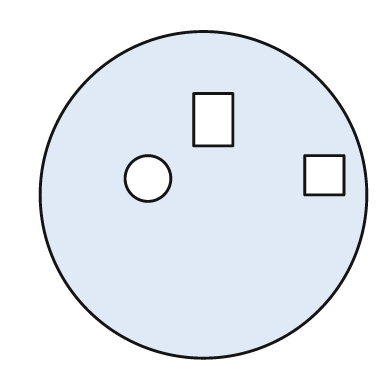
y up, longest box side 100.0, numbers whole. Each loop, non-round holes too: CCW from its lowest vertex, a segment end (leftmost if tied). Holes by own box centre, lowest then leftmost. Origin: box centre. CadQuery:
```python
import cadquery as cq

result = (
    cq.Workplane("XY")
    .moveTo(0.0, 0.0)
    .circle(50.0)
    .moveTo(-17.0, 5.0)
    .circle(7.0)
    .moveTo(31.0, 0.0)
    .lineTo(43.0, 0.0)
    .lineTo(43.0, 12.0)
    .lineTo(31.0, 12.0)
    .close()
    .moveTo(-3.0, 15.0)
    .lineTo(9.0, 15.0)
    .lineTo(9.0, 31.0)
    .lineTo(-3.0, 31.0)
    .close()
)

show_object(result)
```